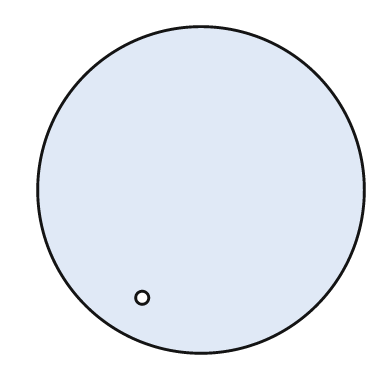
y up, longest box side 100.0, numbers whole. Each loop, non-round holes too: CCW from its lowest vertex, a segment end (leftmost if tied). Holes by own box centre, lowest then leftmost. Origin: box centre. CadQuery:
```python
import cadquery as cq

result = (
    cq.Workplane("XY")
    .moveTo(0.0, 0.0)
    .circle(50.0)
    .moveTo(-18.0, -33.0)
    .circle(2.0)
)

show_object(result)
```